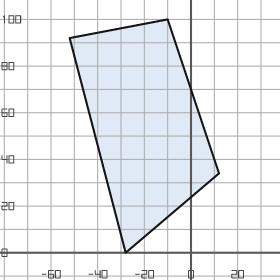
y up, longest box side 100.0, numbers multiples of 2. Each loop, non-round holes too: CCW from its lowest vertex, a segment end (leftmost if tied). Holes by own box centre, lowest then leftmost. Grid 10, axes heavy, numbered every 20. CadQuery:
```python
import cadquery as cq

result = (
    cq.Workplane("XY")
    .moveTo(-28.0, 0.0)
    .lineTo(12.0, 34.0)
    .lineTo(-10.0, 100.0)
    .lineTo(-52.0, 92.0)
    .close()
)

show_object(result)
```